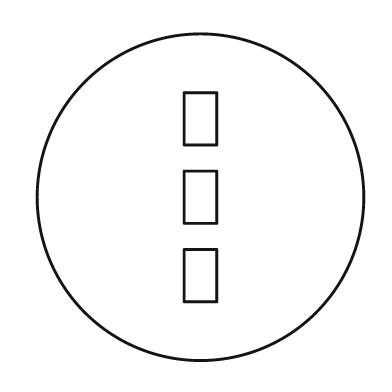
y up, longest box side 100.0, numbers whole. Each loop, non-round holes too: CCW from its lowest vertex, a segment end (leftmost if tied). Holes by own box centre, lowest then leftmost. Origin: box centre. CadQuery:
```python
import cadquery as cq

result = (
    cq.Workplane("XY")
    .moveTo(0.0, 0.0)
    .circle(50.0)
    .moveTo(-5.0, -32.0)
    .lineTo(5.0, -32.0)
    .lineTo(5.0, -16.0)
    .lineTo(-5.0, -16.0)
    .close()
    .moveTo(-5.0, -8.0)
    .lineTo(5.0, -8.0)
    .lineTo(5.0, 8.0)
    .lineTo(-5.0, 8.0)
    .close()
    .moveTo(-5.0, 16.0)
    .lineTo(5.0, 16.0)
    .lineTo(5.0, 32.0)
    .lineTo(-5.0, 32.0)
    .close()
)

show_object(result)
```